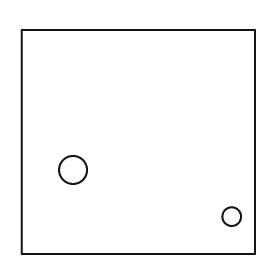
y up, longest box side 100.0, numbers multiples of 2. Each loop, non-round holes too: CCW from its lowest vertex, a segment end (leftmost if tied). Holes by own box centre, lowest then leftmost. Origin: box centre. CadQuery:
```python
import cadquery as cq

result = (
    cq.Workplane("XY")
    .moveTo(-50.0, -48.0)
    .lineTo(50.0, -48.0)
    .lineTo(50.0, 48.0)
    .lineTo(-50.0, 48.0)
    .close()
    .moveTo(40.0, -32.0)
    .circle(4.0)
    .moveTo(-28.0, -12.0)
    .circle(6.0)
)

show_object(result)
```